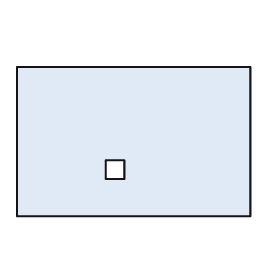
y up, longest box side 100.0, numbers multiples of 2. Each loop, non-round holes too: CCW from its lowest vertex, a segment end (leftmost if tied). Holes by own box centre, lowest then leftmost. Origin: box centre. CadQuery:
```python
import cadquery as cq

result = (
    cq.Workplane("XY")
    .moveTo(-50.0, -32.0)
    .lineTo(50.0, -32.0)
    .lineTo(50.0, 32.0)
    .lineTo(-50.0, 32.0)
    .close()
    .moveTo(-12.0, -16.0)
    .lineTo(-4.0, -16.0)
    .lineTo(-4.0, -8.0)
    .lineTo(-12.0, -8.0)
    .close()
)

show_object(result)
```